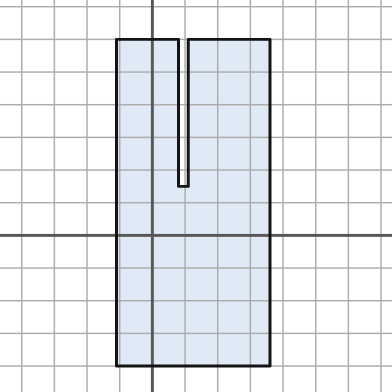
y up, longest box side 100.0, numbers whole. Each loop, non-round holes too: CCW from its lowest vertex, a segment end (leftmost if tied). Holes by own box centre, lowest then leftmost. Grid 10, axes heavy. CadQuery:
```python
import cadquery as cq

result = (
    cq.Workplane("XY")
    .moveTo(-11.0, -40.0)
    .lineTo(36.0, -40.0)
    .lineTo(36.0, 60.0)
    .lineTo(11.0, 60.0)
    .lineTo(11.0, 15.0)
    .lineTo(8.0, 15.0)
    .lineTo(8.0, 60.0)
    .lineTo(-11.0, 60.0)
    .close()
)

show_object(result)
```